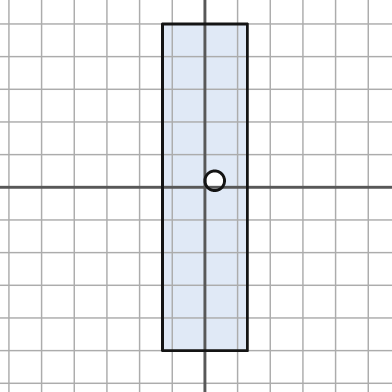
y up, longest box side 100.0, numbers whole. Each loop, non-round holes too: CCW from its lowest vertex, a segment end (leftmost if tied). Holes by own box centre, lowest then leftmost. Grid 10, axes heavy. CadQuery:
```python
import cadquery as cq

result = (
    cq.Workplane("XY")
    .moveTo(-13.0, -50.0)
    .lineTo(13.0, -50.0)
    .lineTo(13.0, 50.0)
    .lineTo(-13.0, 50.0)
    .close()
    .moveTo(3.0, 2.0)
    .circle(3.0)
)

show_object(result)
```